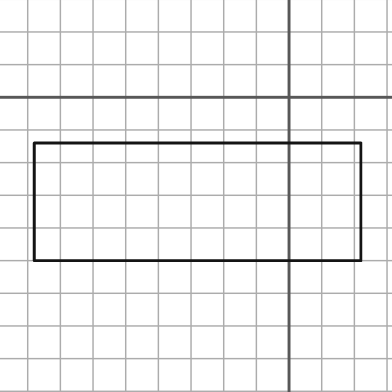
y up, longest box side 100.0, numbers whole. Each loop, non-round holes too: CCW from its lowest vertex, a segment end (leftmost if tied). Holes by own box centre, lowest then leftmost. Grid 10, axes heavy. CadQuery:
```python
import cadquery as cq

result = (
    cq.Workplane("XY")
    .moveTo(-78.0, -50.0)
    .lineTo(22.0, -50.0)
    .lineTo(22.0, -14.0)
    .lineTo(-78.0, -14.0)
    .close()
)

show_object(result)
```